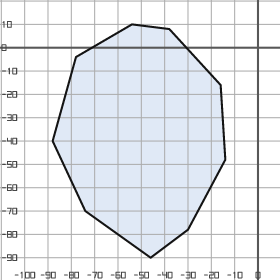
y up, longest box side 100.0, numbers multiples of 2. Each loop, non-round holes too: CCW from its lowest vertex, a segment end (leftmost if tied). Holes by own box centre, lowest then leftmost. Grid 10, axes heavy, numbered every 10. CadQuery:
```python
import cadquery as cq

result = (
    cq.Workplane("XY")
    .moveTo(-46.0, -90.0)
    .lineTo(-30.0, -78.0)
    .lineTo(-14.0, -48.0)
    .lineTo(-16.0, -16.0)
    .lineTo(-38.0, 8.0)
    .lineTo(-54.0, 10.0)
    .lineTo(-78.0, -4.0)
    .lineTo(-88.0, -40.0)
    .lineTo(-74.0, -70.0)
    .close()
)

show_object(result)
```